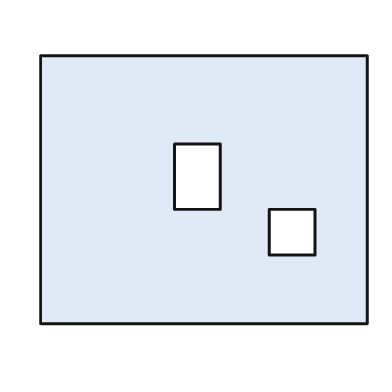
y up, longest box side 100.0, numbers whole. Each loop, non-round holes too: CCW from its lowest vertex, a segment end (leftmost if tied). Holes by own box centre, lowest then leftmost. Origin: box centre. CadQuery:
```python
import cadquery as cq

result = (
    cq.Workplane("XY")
    .moveTo(-50.0, -41.0)
    .lineTo(50.0, -41.0)
    .lineTo(50.0, 41.0)
    .lineTo(-50.0, 41.0)
    .close()
    .moveTo(20.0, -20.0)
    .lineTo(34.0, -20.0)
    .lineTo(34.0, -6.0)
    .lineTo(20.0, -6.0)
    .close()
    .moveTo(-9.0, -6.0)
    .lineTo(5.0, -6.0)
    .lineTo(5.0, 14.0)
    .lineTo(-9.0, 14.0)
    .close()
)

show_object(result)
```